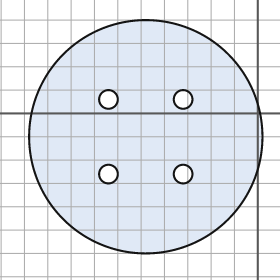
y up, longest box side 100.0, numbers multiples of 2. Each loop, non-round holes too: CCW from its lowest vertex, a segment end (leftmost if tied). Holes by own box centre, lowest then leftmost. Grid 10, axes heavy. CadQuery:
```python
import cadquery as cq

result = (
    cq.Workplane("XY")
    .moveTo(-48.0, -10.0)
    .circle(50.0)
    .moveTo(-64.0, -26.0)
    .circle(4.0)
    .moveTo(-32.0, -26.0)
    .circle(4.0)
    .moveTo(-64.0, 6.0)
    .circle(4.0)
    .moveTo(-32.0, 6.0)
    .circle(4.0)
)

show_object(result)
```